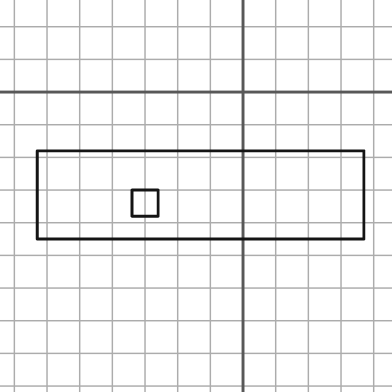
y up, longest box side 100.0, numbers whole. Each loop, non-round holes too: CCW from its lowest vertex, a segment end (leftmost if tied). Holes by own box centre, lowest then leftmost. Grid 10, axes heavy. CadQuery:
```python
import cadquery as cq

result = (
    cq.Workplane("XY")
    .moveTo(-63.0, -45.0)
    .lineTo(37.0, -45.0)
    .lineTo(37.0, -18.0)
    .lineTo(-63.0, -18.0)
    .close()
    .moveTo(-34.0, -38.0)
    .lineTo(-26.0, -38.0)
    .lineTo(-26.0, -30.0)
    .lineTo(-34.0, -30.0)
    .close()
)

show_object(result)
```